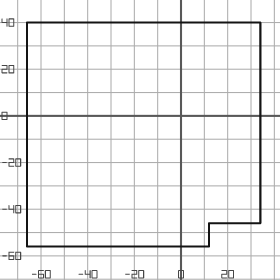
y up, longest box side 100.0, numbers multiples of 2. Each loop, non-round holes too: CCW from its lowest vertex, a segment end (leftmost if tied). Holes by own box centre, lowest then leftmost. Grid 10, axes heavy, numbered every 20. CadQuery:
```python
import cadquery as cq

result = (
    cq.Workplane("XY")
    .moveTo(-66.0, -56.0)
    .lineTo(12.0, -56.0)
    .lineTo(12.0, -46.0)
    .lineTo(34.0, -46.0)
    .lineTo(34.0, 40.0)
    .lineTo(-66.0, 40.0)
    .close()
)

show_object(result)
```